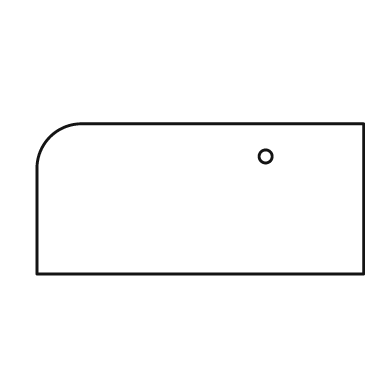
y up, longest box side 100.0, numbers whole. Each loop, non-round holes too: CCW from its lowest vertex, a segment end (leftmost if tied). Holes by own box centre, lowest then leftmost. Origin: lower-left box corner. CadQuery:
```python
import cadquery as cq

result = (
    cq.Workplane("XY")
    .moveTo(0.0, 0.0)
    .lineTo(100.0, 0.0)
    .lineTo(100.0, 46.0)
    .lineTo(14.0, 46.0)
    .threePointArc((4.0, 42.0), (0.0, 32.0))
    .close()
    .moveTo(70.0, 36.0)
    .circle(2.0)
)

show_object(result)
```